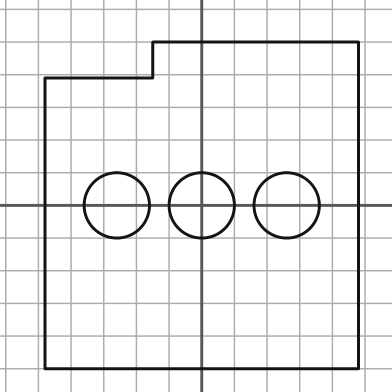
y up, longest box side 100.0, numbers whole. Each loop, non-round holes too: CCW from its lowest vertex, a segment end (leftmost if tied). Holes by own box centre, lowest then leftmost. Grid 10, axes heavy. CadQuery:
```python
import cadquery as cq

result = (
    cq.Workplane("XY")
    .moveTo(-48.0, -50.0)
    .lineTo(48.0, -50.0)
    .lineTo(48.0, 50.0)
    .lineTo(-15.0, 50.0)
    .lineTo(-15.0, 39.0)
    .lineTo(-48.0, 39.0)
    .close()
    .moveTo(-26.0, 0.0)
    .circle(10.0)
    .moveTo(0.0, 0.0)
    .circle(10.0)
    .moveTo(26.0, 0.0)
    .circle(10.0)
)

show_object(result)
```